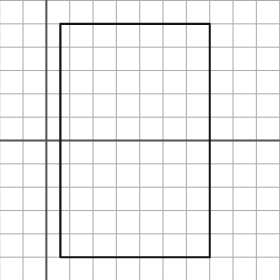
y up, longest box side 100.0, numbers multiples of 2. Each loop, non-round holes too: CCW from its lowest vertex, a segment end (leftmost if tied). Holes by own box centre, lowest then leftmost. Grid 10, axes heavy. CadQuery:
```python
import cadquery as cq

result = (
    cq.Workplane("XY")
    .moveTo(6.0, -50.0)
    .lineTo(70.0, -50.0)
    .lineTo(70.0, 50.0)
    .lineTo(6.0, 50.0)
    .close()
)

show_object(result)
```